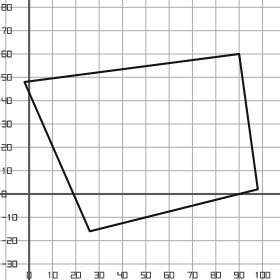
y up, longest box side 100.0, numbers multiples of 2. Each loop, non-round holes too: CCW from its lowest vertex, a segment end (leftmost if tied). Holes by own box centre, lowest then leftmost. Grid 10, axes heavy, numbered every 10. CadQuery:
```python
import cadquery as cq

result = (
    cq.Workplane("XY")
    .moveTo(26.0, -16.0)
    .lineTo(98.0, 2.0)
    .lineTo(90.0, 60.0)
    .lineTo(-2.0, 48.0)
    .close()
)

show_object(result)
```